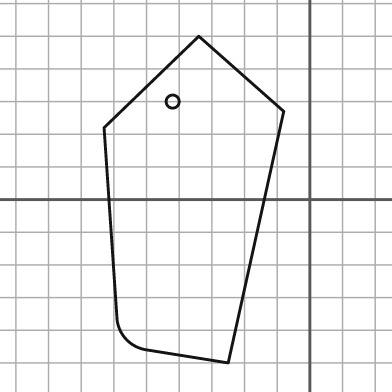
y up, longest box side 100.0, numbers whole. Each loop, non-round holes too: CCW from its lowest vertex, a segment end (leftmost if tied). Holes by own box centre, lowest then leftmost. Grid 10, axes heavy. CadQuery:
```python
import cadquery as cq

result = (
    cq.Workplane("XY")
    .moveTo(-25.0, -50.0)
    .lineTo(-8.0, 27.0)
    .lineTo(-34.0, 50.0)
    .lineTo(-63.0, 22.0)
    .lineTo(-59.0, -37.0)
    .threePointArc((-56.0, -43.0), (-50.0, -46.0))
    .close()
    .moveTo(-42.0, 30.0)
    .circle(2.0)
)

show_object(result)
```